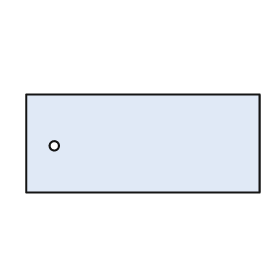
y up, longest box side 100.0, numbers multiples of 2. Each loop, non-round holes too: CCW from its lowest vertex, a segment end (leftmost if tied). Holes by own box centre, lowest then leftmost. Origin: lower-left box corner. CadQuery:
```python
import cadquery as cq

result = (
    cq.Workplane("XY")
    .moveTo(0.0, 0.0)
    .lineTo(100.0, 0.0)
    .lineTo(100.0, 42.0)
    .lineTo(0.0, 42.0)
    .close()
    .moveTo(12.0, 20.0)
    .circle(2.0)
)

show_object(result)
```